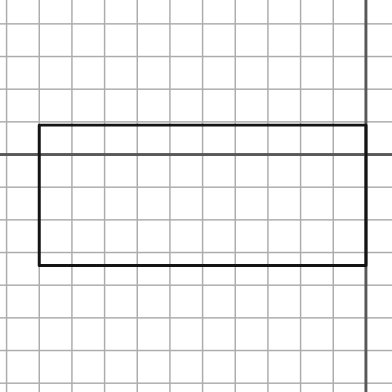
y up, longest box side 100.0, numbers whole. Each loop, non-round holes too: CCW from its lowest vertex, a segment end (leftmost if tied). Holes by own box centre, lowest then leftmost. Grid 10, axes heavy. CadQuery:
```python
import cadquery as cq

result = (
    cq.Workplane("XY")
    .moveTo(-100.0, -34.0)
    .lineTo(0.0, -34.0)
    .lineTo(0.0, 9.0)
    .lineTo(-100.0, 9.0)
    .close()
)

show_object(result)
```